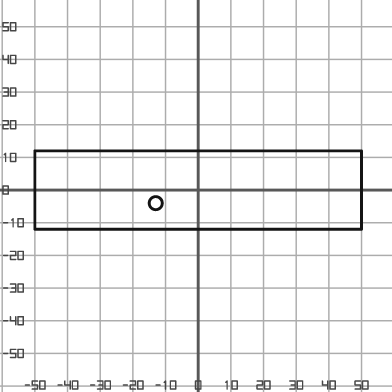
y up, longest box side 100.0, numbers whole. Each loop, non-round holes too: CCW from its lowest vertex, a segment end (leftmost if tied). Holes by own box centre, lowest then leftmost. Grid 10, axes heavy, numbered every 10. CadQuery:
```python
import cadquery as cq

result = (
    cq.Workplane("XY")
    .moveTo(-50.0, -12.0)
    .lineTo(50.0, -12.0)
    .lineTo(50.0, 12.0)
    .lineTo(-50.0, 12.0)
    .close()
    .moveTo(-13.0, -4.0)
    .circle(2.0)
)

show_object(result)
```